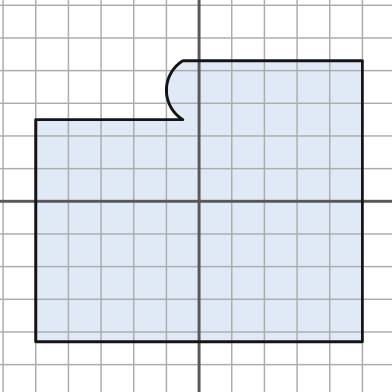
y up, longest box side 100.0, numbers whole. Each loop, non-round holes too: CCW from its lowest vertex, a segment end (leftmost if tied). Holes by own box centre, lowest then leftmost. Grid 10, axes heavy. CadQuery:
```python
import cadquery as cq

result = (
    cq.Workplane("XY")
    .moveTo(-50.0, -43.0)
    .lineTo(50.0, -43.0)
    .lineTo(50.0, 43.0)
    .lineTo(-5.0, 43.0)
    .threePointArc((-10.0, 34.0), (-5.0, 25.0))
    .lineTo(-50.0, 25.0)
    .close()
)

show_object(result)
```